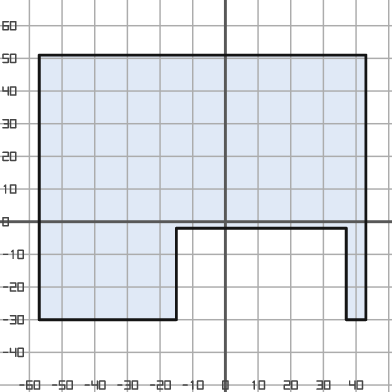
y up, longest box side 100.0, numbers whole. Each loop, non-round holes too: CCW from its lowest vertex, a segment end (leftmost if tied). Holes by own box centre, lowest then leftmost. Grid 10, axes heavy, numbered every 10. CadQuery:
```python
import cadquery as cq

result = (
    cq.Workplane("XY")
    .moveTo(-57.0, -30.0)
    .lineTo(-15.0, -30.0)
    .lineTo(-15.0, -2.0)
    .lineTo(37.0, -2.0)
    .lineTo(37.0, -30.0)
    .lineTo(43.0, -30.0)
    .lineTo(43.0, 51.0)
    .lineTo(-57.0, 51.0)
    .close()
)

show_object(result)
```